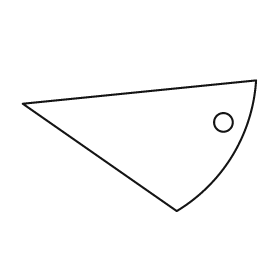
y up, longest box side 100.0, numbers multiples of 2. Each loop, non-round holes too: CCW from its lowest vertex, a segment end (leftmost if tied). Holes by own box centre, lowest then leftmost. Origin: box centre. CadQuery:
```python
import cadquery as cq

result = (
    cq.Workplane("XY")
    .moveTo(16.0, -28.0)
    .threePointArc((40.0, -4.0), (50.0, 28.0))
    .lineTo(-50.0, 18.0)
    .close()
    .moveTo(36.0, 10.0)
    .circle(4.0)
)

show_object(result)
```